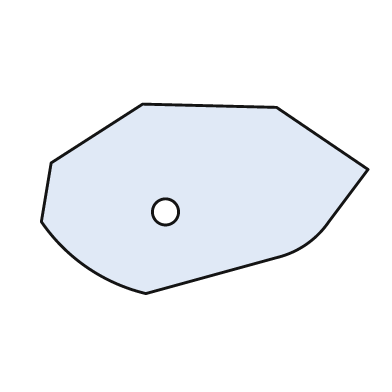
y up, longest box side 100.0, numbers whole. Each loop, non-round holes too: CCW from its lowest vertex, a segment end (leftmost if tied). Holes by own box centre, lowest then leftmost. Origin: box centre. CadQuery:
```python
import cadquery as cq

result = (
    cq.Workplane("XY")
    .moveTo(-18.0, -29.0)
    .lineTo(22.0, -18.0)
    .threePointArc((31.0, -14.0), (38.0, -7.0))
    .lineTo(50.0, 9.0)
    .lineTo(22.0, 28.0)
    .lineTo(-19.0, 29.0)
    .lineTo(-47.0, 11.0)
    .lineTo(-50.0, -7.0)
    .threePointArc((-36.0, -21.0), (-18.0, -29.0))
    .close()
    .moveTo(-12.0, -4.0)
    .circle(4.0)
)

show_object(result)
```